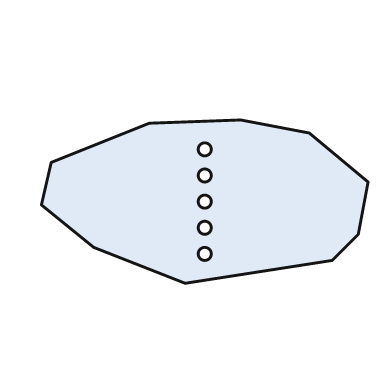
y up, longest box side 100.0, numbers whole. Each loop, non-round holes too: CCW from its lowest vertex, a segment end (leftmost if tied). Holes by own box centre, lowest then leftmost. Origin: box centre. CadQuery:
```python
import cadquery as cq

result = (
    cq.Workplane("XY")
    .moveTo(-6.0, -25.0)
    .lineTo(39.0, -18.0)
    .lineTo(47.0, -10.0)
    .lineTo(50.0, 6.0)
    .lineTo(32.0, 21.0)
    .lineTo(11.0, 25.0)
    .lineTo(-17.0, 24.0)
    .lineTo(-47.0, 12.0)
    .lineTo(-50.0, -1.0)
    .lineTo(-34.0, -14.0)
    .close()
    .moveTo(0.0, -16.0)
    .circle(2.0)
    .moveTo(0.0, -8.0)
    .circle(2.0)
    .moveTo(0.0, 0.0)
    .circle(2.0)
    .moveTo(0.0, 8.0)
    .circle(2.0)
    .moveTo(0.0, 16.0)
    .circle(2.0)
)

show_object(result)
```